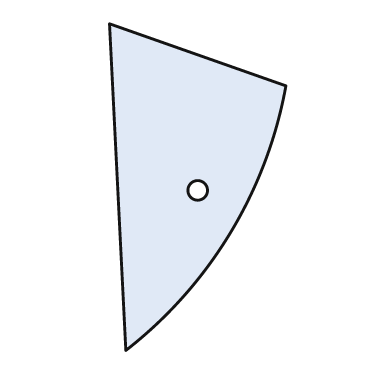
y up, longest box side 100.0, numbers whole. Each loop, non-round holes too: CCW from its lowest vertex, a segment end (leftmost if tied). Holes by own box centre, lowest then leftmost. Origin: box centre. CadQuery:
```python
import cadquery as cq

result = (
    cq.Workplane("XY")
    .moveTo(-22.0, -50.0)
    .threePointArc((10.0, -14.0), (27.0, 31.0))
    .lineTo(-27.0, 50.0)
    .close()
    .moveTo(0.0, -1.0)
    .circle(3.0)
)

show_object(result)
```